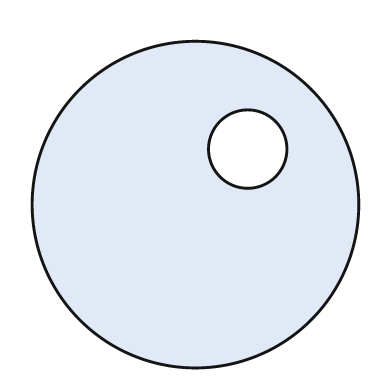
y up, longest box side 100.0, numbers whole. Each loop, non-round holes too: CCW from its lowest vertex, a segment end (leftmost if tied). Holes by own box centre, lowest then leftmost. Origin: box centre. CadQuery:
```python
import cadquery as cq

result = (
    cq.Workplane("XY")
    .moveTo(0.0, 0.0)
    .circle(50.0)
    .moveTo(16.0, 17.0)
    .circle(12.0)
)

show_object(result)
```